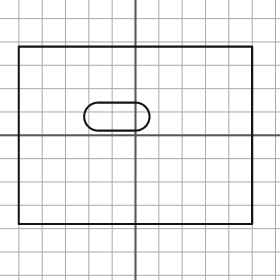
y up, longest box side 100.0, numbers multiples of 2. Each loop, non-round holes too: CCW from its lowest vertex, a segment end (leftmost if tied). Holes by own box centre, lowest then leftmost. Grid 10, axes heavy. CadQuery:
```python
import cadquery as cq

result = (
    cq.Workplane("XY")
    .moveTo(-50.0, -38.0)
    .lineTo(50.0, -38.0)
    .lineTo(50.0, 38.0)
    .lineTo(-50.0, 38.0)
    .close()
    .moveTo(-16.0, 2.0)
    .lineTo(0.0, 2.0)
    .threePointArc((6.0, 8.0), (0.0, 14.0))
    .lineTo(-16.0, 14.0)
    .threePointArc((-22.0, 8.0), (-16.0, 2.0))
    .close()
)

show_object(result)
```